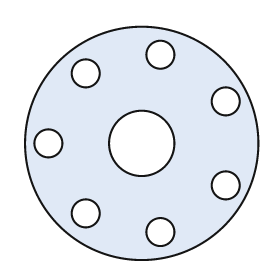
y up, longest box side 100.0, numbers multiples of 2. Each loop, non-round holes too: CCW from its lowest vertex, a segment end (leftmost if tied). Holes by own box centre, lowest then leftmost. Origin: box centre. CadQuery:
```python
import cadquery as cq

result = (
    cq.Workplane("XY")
    .moveTo(0.0, 0.0)
    .circle(50.0)
    .moveTo(8.0, -38.0)
    .circle(6.0)
    .moveTo(-24.0, -30.0)
    .circle(6.0)
    .moveTo(36.0, -18.0)
    .circle(6.0)
    .moveTo(-40.0, 0.0)
    .circle(6.0)
    .moveTo(0.0, 0.0)
    .circle(14.0)
    .moveTo(36.0, 18.0)
    .circle(6.0)
    .moveTo(-24.0, 30.0)
    .circle(6.0)
    .moveTo(8.0, 38.0)
    .circle(6.0)
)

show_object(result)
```